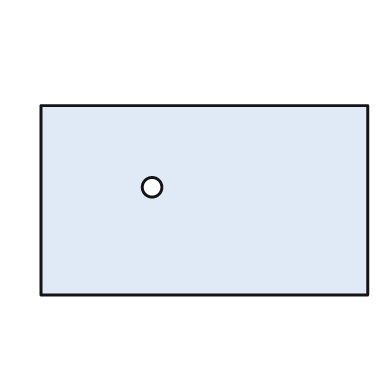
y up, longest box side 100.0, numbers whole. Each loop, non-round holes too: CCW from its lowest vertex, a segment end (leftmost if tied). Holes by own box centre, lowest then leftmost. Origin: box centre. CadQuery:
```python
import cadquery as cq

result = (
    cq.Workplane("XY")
    .moveTo(-50.0, -29.0)
    .lineTo(50.0, -29.0)
    .lineTo(50.0, 29.0)
    .lineTo(-50.0, 29.0)
    .close()
    .moveTo(-16.0, 4.0)
    .circle(3.0)
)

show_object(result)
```